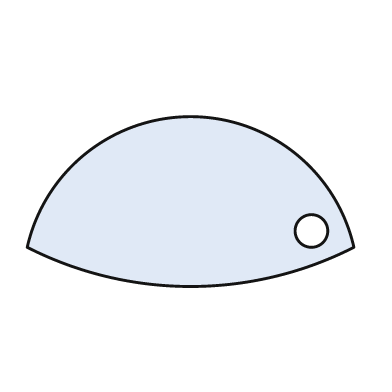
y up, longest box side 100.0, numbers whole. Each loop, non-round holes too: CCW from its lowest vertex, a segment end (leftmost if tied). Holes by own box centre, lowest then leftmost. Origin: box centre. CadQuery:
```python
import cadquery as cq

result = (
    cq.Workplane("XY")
    .moveTo(-50.0, -14.0)
    .threePointArc((0.0, -26.0), (50.0, -14.0))
    .threePointArc((0.0, 26.0), (-50.0, -14.0))
    .close()
    .moveTo(37.0, -9.0)
    .circle(5.0)
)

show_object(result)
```